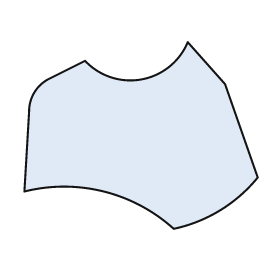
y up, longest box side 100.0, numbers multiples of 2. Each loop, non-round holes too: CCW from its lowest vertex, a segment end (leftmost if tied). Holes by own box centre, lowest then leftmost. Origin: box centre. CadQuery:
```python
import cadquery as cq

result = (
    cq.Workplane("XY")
    .moveTo(14.0, -40.0)
    .threePointArc((34.0, -32.0), (50.0, -18.0))
    .lineTo(36.0, 22.0)
    .lineTo(20.0, 40.0)
    .threePointArc((0.0, 24.0), (-24.0, 32.0))
    .lineTo(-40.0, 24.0)
    .threePointArc((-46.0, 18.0), (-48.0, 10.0))
    .lineTo(-50.0, -24.0)
    .threePointArc((-16.0, -24.0), (14.0, -40.0))
    .close()
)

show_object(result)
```